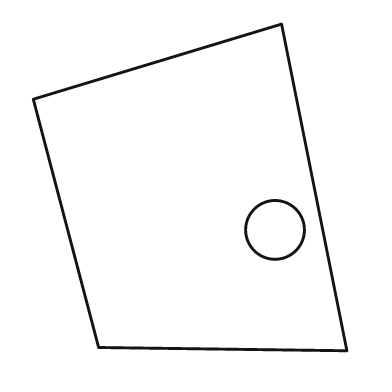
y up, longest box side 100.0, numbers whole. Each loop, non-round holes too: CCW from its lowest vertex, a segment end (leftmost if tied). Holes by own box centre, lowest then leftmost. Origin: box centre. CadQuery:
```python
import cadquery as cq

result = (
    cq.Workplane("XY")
    .moveTo(48.0, -50.0)
    .lineTo(28.0, 50.0)
    .lineTo(-48.0, 27.0)
    .lineTo(-28.0, -49.0)
    .close()
    .moveTo(26.0, -13.0)
    .circle(9.0)
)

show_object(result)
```